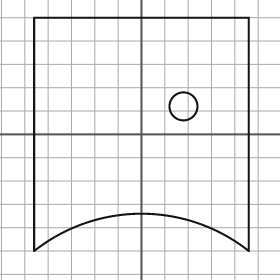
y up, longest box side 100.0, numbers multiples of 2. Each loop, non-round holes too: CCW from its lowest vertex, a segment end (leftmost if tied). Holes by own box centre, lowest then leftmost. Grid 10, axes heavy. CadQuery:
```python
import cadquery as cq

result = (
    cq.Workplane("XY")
    .moveTo(-46.0, -50.0)
    .threePointArc((0.0, -34.0), (46.0, -50.0))
    .lineTo(46.0, 50.0)
    .lineTo(-46.0, 50.0)
    .close()
    .moveTo(18.0, 12.0)
    .circle(6.0)
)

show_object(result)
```